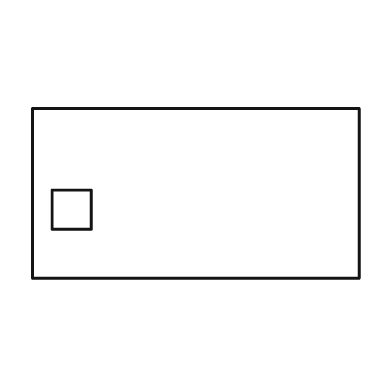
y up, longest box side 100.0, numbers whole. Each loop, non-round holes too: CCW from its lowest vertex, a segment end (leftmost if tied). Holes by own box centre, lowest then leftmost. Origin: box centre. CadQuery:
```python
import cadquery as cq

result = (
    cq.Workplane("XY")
    .moveTo(-50.0, -26.0)
    .lineTo(50.0, -26.0)
    .lineTo(50.0, 26.0)
    .lineTo(-50.0, 26.0)
    .close()
    .moveTo(-44.0, -11.0)
    .lineTo(-32.0, -11.0)
    .lineTo(-32.0, 1.0)
    .lineTo(-44.0, 1.0)
    .close()
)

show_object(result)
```